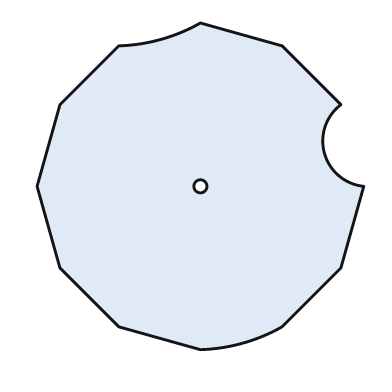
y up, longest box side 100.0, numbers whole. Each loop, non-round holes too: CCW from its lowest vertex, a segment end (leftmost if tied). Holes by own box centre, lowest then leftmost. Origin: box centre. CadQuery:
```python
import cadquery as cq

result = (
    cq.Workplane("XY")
    .moveTo(0.0, -50.0)
    .threePointArc((13.0, -48.0), (25.0, -43.0))
    .lineTo(43.0, -25.0)
    .lineTo(50.0, 0.0)
    .threePointArc((38.0, 10.0), (43.0, 25.0))
    .lineTo(25.0, 43.0)
    .lineTo(0.0, 50.0)
    .threePointArc((-12.0, 45.0), (-25.0, 43.0))
    .lineTo(-43.0, 25.0)
    .lineTo(-50.0, 0.0)
    .lineTo(-43.0, -25.0)
    .lineTo(-25.0, -43.0)
    .close()
    .moveTo(0.0, 0.0)
    .circle(2.0)
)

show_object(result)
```